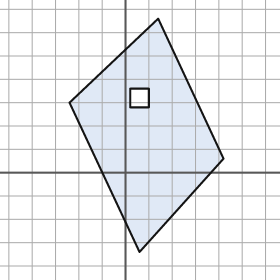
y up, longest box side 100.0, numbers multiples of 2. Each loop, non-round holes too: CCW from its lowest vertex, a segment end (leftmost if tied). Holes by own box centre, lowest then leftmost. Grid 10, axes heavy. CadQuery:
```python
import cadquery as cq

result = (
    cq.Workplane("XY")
    .moveTo(6.0, -34.0)
    .lineTo(42.0, 6.0)
    .lineTo(14.0, 66.0)
    .lineTo(-24.0, 30.0)
    .close()
    .moveTo(2.0, 28.0)
    .lineTo(10.0, 28.0)
    .lineTo(10.0, 36.0)
    .lineTo(2.0, 36.0)
    .close()
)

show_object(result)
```